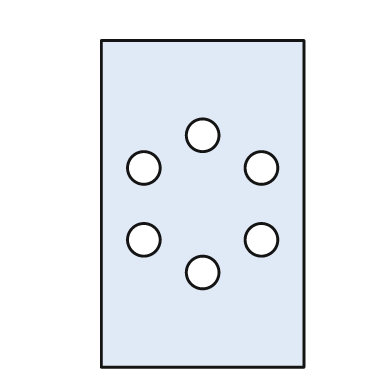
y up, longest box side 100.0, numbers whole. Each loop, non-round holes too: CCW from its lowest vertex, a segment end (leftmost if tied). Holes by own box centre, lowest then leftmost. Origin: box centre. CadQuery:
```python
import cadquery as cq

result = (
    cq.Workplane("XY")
    .moveTo(-31.0, -50.0)
    .lineTo(31.0, -50.0)
    .lineTo(31.0, 50.0)
    .lineTo(-31.0, 50.0)
    .close()
    .moveTo(0.0, -21.0)
    .circle(5.0)
    .moveTo(-18.0, -11.0)
    .circle(5.0)
    .moveTo(18.0, -11.0)
    .circle(5.0)
    .moveTo(-18.0, 11.0)
    .circle(5.0)
    .moveTo(18.0, 11.0)
    .circle(5.0)
    .moveTo(0.0, 21.0)
    .circle(5.0)
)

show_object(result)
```